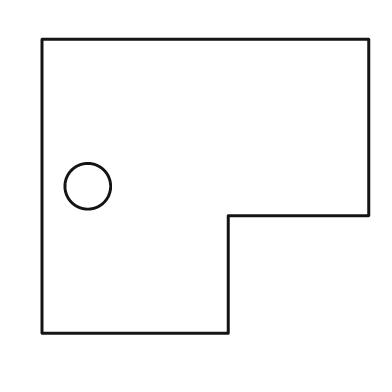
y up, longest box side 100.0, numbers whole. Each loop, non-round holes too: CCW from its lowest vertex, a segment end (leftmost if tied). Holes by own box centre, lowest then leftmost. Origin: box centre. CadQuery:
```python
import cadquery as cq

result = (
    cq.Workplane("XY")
    .moveTo(-50.0, -45.0)
    .lineTo(7.0, -45.0)
    .lineTo(7.0, -9.0)
    .lineTo(50.0, -9.0)
    .lineTo(50.0, 45.0)
    .lineTo(-50.0, 45.0)
    .close()
    .moveTo(-36.0, 0.0)
    .circle(7.0)
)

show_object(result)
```